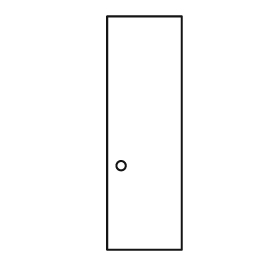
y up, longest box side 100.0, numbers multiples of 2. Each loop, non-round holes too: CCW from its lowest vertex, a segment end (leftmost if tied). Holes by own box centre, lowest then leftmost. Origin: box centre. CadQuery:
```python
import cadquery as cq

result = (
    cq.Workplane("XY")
    .moveTo(-16.0, -50.0)
    .lineTo(16.0, -50.0)
    .lineTo(16.0, 50.0)
    .lineTo(-16.0, 50.0)
    .close()
    .moveTo(-10.0, -14.0)
    .circle(2.0)
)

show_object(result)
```